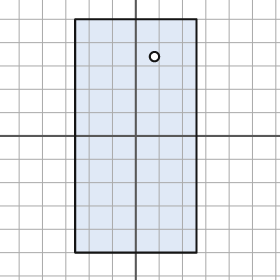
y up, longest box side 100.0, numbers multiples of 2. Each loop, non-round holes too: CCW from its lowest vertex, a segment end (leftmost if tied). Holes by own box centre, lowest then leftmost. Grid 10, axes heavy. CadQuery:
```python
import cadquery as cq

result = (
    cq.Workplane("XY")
    .moveTo(-26.0, -50.0)
    .lineTo(26.0, -50.0)
    .lineTo(26.0, 50.0)
    .lineTo(-26.0, 50.0)
    .close()
    .moveTo(8.0, 34.0)
    .circle(2.0)
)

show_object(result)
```